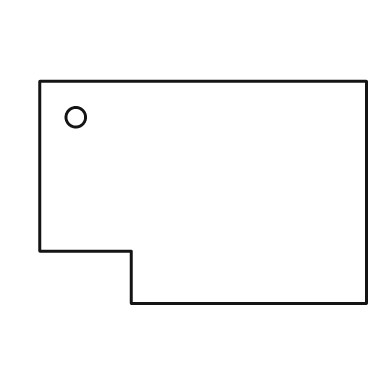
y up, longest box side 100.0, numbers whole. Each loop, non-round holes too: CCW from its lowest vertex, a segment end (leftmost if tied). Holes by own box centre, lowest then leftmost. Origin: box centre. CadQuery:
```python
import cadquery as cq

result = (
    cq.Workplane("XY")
    .moveTo(-22.0, -34.0)
    .lineTo(50.0, -34.0)
    .lineTo(50.0, 34.0)
    .lineTo(-50.0, 34.0)
    .lineTo(-50.0, -18.0)
    .lineTo(-22.0, -18.0)
    .close()
    .moveTo(-39.0, 23.0)
    .circle(3.0)
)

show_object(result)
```